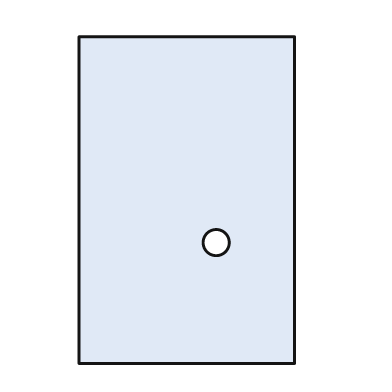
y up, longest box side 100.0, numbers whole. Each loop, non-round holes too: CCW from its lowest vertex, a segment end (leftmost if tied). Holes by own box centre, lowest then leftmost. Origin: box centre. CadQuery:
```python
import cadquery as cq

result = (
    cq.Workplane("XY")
    .moveTo(-33.0, -50.0)
    .lineTo(33.0, -50.0)
    .lineTo(33.0, 50.0)
    .lineTo(-33.0, 50.0)
    .close()
    .moveTo(9.0, -13.0)
    .circle(4.0)
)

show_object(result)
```